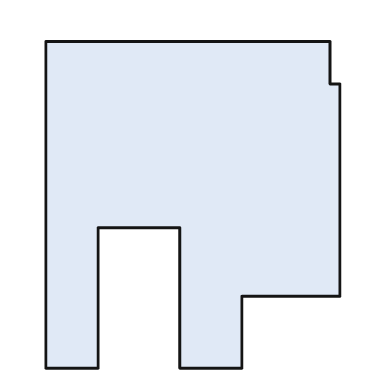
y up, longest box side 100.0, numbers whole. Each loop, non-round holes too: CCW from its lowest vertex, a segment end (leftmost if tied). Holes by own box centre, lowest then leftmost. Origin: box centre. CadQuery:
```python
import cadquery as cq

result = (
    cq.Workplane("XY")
    .moveTo(-45.0, -50.0)
    .lineTo(-29.0, -50.0)
    .lineTo(-29.0, -7.0)
    .lineTo(-4.0, -7.0)
    .lineTo(-4.0, -50.0)
    .lineTo(15.0, -50.0)
    .lineTo(15.0, -28.0)
    .lineTo(45.0, -28.0)
    .lineTo(45.0, 37.0)
    .lineTo(42.0, 37.0)
    .lineTo(42.0, 50.0)
    .lineTo(-45.0, 50.0)
    .close()
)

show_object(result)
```